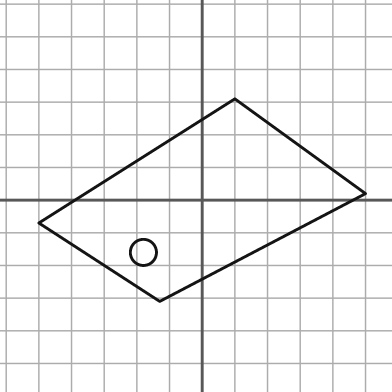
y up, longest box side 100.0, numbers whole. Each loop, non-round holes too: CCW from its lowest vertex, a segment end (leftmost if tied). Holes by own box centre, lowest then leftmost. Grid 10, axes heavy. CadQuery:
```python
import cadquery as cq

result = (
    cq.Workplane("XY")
    .moveTo(-13.0, -31.0)
    .lineTo(50.0, 2.0)
    .lineTo(10.0, 31.0)
    .lineTo(-50.0, -7.0)
    .close()
    .moveTo(-18.0, -16.0)
    .circle(4.0)
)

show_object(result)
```